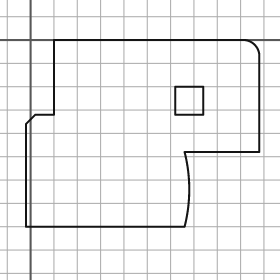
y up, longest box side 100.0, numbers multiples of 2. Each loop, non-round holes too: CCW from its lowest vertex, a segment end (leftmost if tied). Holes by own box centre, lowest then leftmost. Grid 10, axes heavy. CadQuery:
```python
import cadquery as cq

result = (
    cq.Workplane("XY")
    .moveTo(-2.0, -80.0)
    .lineTo(66.0, -80.0)
    .threePointArc((68.0, -64.0), (66.0, -48.0))
    .lineTo(98.0, -48.0)
    .lineTo(98.0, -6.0)
    .threePointArc((96.0, -2.0), (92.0, 0.0))
    .lineTo(10.0, 0.0)
    .lineTo(10.0, -32.0)
    .lineTo(2.0, -32.0)
    .lineTo(-2.0, -36.0)
    .close()
    .moveTo(62.0, -32.0)
    .lineTo(74.0, -32.0)
    .lineTo(74.0, -20.0)
    .lineTo(62.0, -20.0)
    .close()
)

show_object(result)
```